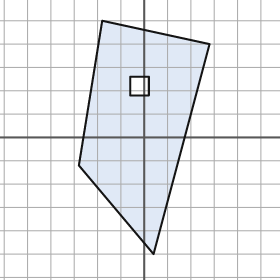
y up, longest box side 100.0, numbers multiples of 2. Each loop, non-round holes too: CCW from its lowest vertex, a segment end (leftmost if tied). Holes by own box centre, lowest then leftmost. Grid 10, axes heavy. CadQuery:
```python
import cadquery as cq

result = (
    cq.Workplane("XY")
    .moveTo(4.0, -50.0)
    .lineTo(28.0, 40.0)
    .lineTo(-18.0, 50.0)
    .lineTo(-28.0, -12.0)
    .close()
    .moveTo(-6.0, 18.0)
    .lineTo(2.0, 18.0)
    .lineTo(2.0, 26.0)
    .lineTo(-6.0, 26.0)
    .close()
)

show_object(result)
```